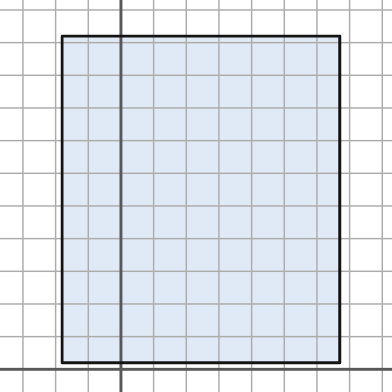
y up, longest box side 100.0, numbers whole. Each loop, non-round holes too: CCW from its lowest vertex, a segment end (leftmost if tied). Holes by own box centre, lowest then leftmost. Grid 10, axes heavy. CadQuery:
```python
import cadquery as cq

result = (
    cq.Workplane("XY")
    .moveTo(-18.0, 2.0)
    .lineTo(67.0, 2.0)
    .lineTo(67.0, 102.0)
    .lineTo(-18.0, 102.0)
    .close()
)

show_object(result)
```